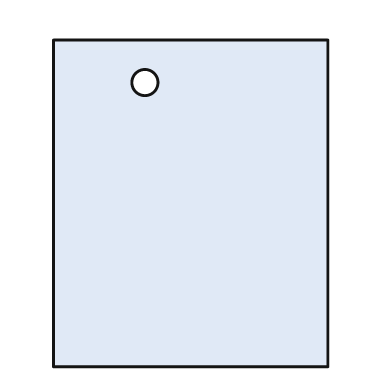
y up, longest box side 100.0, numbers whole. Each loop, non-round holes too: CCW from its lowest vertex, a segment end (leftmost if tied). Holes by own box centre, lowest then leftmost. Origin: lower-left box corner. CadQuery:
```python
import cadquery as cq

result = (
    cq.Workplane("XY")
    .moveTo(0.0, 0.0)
    .lineTo(84.0, 0.0)
    .lineTo(84.0, 100.0)
    .lineTo(0.0, 100.0)
    .close()
    .moveTo(28.0, 87.0)
    .circle(4.0)
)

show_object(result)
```